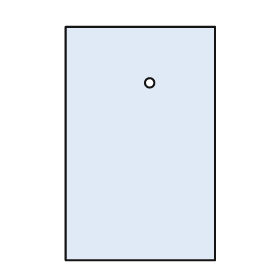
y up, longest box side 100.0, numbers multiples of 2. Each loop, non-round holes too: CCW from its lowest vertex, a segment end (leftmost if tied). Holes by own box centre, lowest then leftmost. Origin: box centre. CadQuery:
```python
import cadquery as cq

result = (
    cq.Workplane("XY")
    .moveTo(-32.0, -50.0)
    .lineTo(32.0, -50.0)
    .lineTo(32.0, 50.0)
    .lineTo(-32.0, 50.0)
    .close()
    .moveTo(4.0, 26.0)
    .circle(2.0)
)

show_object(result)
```